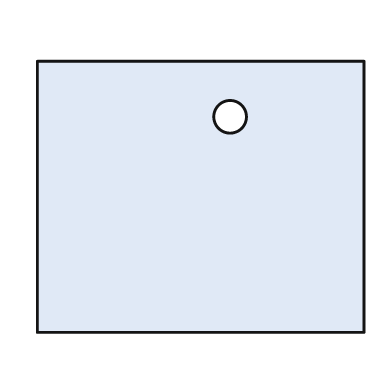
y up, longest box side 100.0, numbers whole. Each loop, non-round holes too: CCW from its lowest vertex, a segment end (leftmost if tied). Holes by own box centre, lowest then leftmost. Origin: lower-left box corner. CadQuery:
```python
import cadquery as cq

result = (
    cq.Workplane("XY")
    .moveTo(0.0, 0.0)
    .lineTo(100.0, 0.0)
    .lineTo(100.0, 83.0)
    .lineTo(0.0, 83.0)
    .close()
    .moveTo(59.0, 66.0)
    .circle(5.0)
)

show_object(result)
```